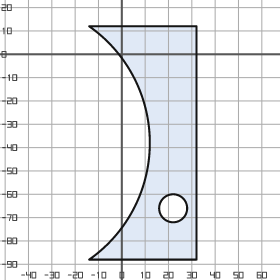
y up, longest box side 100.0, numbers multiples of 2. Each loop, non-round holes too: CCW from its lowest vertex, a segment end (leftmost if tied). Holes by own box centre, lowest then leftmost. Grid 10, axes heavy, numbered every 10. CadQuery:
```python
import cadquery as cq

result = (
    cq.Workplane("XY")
    .moveTo(-14.0, -88.0)
    .lineTo(32.0, -88.0)
    .lineTo(32.0, 12.0)
    .lineTo(-14.0, 12.0)
    .threePointArc((12.0, -38.0), (-14.0, -88.0))
    .close()
    .moveTo(22.0, -66.0)
    .circle(6.0)
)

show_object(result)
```